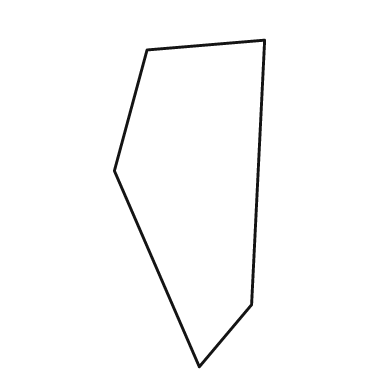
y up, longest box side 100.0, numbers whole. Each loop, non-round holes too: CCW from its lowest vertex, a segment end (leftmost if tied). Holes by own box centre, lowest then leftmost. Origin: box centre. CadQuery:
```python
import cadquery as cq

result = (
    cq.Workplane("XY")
    .moveTo(3.0, -50.0)
    .lineTo(19.0, -31.0)
    .lineTo(23.0, 50.0)
    .lineTo(-13.0, 47.0)
    .lineTo(-23.0, 10.0)
    .close()
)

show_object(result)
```